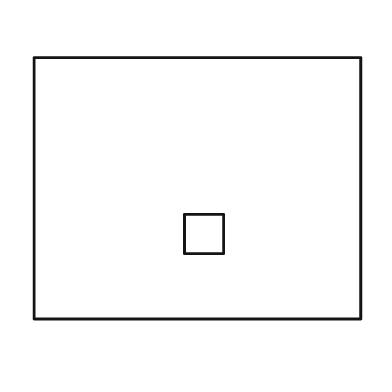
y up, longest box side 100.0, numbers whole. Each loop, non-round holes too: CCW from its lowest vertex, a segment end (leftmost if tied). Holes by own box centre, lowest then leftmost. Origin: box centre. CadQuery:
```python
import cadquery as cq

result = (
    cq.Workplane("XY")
    .moveTo(-50.0, -40.0)
    .lineTo(50.0, -40.0)
    .lineTo(50.0, 40.0)
    .lineTo(-50.0, 40.0)
    .close()
    .moveTo(-4.0, -20.0)
    .lineTo(8.0, -20.0)
    .lineTo(8.0, -8.0)
    .lineTo(-4.0, -8.0)
    .close()
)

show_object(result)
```